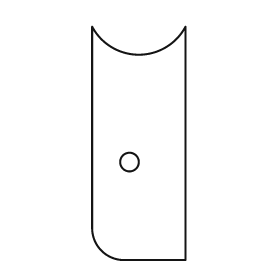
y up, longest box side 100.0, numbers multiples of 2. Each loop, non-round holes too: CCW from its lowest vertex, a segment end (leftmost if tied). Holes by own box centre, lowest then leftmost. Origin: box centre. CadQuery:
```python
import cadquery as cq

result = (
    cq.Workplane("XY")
    .moveTo(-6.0, -50.0)
    .lineTo(20.0, -50.0)
    .lineTo(20.0, 50.0)
    .threePointArc((0.0, 38.0), (-20.0, 50.0))
    .lineTo(-20.0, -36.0)
    .threePointArc((-16.0, -46.0), (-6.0, -50.0))
    .close()
    .moveTo(-4.0, -8.0)
    .circle(4.0)
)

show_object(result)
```